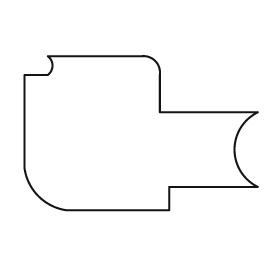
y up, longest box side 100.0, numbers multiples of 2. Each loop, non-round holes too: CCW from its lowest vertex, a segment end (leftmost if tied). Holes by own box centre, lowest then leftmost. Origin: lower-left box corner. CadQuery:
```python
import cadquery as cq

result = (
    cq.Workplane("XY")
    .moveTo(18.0, 0.0)
    .lineTo(62.0, 0.0)
    .lineTo(62.0, 10.0)
    .lineTo(100.0, 10.0)
    .threePointArc((90.0, 26.0), (100.0, 42.0))
    .lineTo(58.0, 42.0)
    .lineTo(58.0, 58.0)
    .threePointArc((56.0, 64.0), (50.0, 66.0))
    .lineTo(10.0, 66.0)
    .threePointArc((12.0, 62.0), (10.0, 58.0))
    .lineTo(0.0, 58.0)
    .lineTo(0.0, 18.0)
    .threePointArc((6.0, 6.0), (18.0, 0.0))
    .close()
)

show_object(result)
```